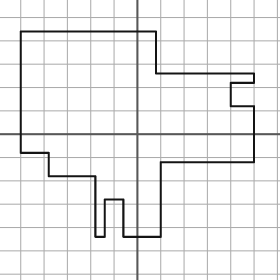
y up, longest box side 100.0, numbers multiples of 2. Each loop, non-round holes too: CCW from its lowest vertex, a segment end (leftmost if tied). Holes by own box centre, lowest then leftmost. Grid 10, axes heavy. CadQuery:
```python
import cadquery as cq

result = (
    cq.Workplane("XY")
    .moveTo(-18.0, -44.0)
    .lineTo(-14.0, -44.0)
    .lineTo(-14.0, -28.0)
    .lineTo(-6.0, -28.0)
    .lineTo(-6.0, -44.0)
    .lineTo(10.0, -44.0)
    .lineTo(10.0, -12.0)
    .lineTo(50.0, -12.0)
    .lineTo(50.0, 12.0)
    .lineTo(40.0, 12.0)
    .lineTo(40.0, 22.0)
    .lineTo(50.0, 22.0)
    .lineTo(50.0, 26.0)
    .lineTo(8.0, 26.0)
    .lineTo(8.0, 44.0)
    .lineTo(-50.0, 44.0)
    .lineTo(-50.0, -8.0)
    .lineTo(-38.0, -8.0)
    .lineTo(-38.0, -18.0)
    .lineTo(-18.0, -18.0)
    .close()
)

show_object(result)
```